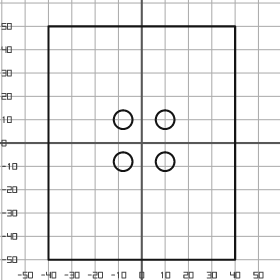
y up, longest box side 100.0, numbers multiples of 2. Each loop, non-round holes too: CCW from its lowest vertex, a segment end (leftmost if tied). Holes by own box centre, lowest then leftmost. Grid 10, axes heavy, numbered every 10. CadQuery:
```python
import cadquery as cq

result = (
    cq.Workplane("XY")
    .moveTo(-40.0, -50.0)
    .lineTo(40.0, -50.0)
    .lineTo(40.0, 50.0)
    .lineTo(-40.0, 50.0)
    .close()
    .moveTo(-8.0, -8.0)
    .circle(4.0)
    .moveTo(10.0, -8.0)
    .circle(4.0)
    .moveTo(-8.0, 10.0)
    .circle(4.0)
    .moveTo(10.0, 10.0)
    .circle(4.0)
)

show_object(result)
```